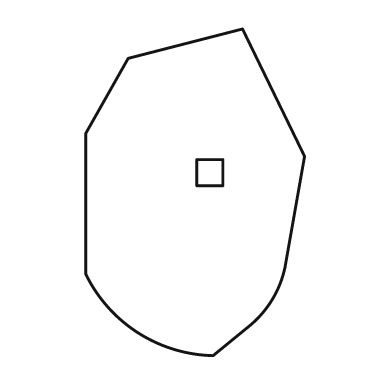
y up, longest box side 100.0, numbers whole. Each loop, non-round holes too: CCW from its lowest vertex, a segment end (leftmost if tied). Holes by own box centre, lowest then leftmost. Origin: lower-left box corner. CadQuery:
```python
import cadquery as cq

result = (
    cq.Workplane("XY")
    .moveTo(39.0, 0.0)
    .lineTo(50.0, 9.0)
    .threePointArc((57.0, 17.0), (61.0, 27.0))
    .lineTo(67.0, 61.0)
    .lineTo(48.0, 100.0)
    .lineTo(13.0, 91.0)
    .lineTo(0.0, 68.0)
    .lineTo(0.0, 25.0)
    .threePointArc((16.0, 7.0), (39.0, 0.0))
    .close()
    .moveTo(34.0, 52.0)
    .lineTo(42.0, 52.0)
    .lineTo(42.0, 60.0)
    .lineTo(34.0, 60.0)
    .close()
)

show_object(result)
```